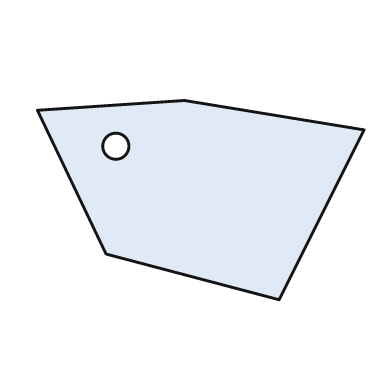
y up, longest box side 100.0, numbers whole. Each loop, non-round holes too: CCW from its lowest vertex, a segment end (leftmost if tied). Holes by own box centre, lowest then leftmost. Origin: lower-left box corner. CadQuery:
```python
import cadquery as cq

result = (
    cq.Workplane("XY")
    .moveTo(74.0, 0.0)
    .lineTo(100.0, 52.0)
    .lineTo(45.0, 61.0)
    .lineTo(0.0, 58.0)
    .lineTo(21.0, 14.0)
    .close()
    .moveTo(24.0, 47.0)
    .circle(4.0)
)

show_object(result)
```